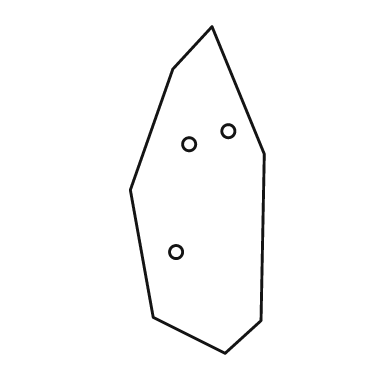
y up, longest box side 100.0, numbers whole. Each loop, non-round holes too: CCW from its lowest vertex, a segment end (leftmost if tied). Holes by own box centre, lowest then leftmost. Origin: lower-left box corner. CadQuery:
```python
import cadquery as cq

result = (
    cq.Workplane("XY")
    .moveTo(29.0, 0.0)
    .lineTo(40.0, 10.0)
    .lineTo(41.0, 61.0)
    .lineTo(25.0, 100.0)
    .lineTo(13.0, 87.0)
    .lineTo(0.0, 50.0)
    .lineTo(7.0, 11.0)
    .close()
    .moveTo(14.0, 31.0)
    .circle(2.0)
    .moveTo(18.0, 64.0)
    .circle(2.0)
    .moveTo(30.0, 68.0)
    .circle(2.0)
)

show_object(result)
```